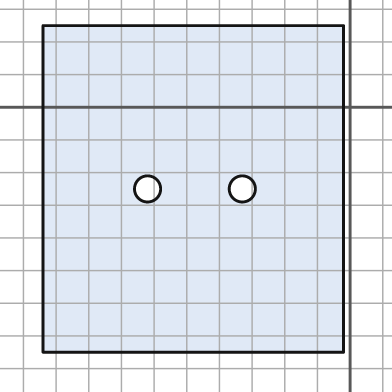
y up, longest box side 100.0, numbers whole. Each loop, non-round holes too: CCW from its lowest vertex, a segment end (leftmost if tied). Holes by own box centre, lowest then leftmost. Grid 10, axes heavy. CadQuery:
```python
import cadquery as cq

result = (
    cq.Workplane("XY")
    .moveTo(-94.0, -75.0)
    .lineTo(-2.0, -75.0)
    .lineTo(-2.0, 25.0)
    .lineTo(-94.0, 25.0)
    .close()
    .moveTo(-62.0, -25.0)
    .circle(4.0)
    .moveTo(-33.0, -25.0)
    .circle(4.0)
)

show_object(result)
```